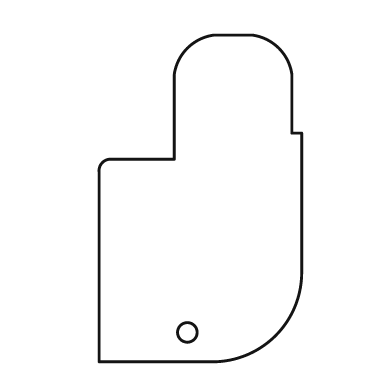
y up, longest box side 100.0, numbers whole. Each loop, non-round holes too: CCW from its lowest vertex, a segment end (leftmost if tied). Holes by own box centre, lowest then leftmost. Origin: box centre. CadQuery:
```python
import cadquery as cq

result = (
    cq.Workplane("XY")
    .moveTo(-31.0, -50.0)
    .lineTo(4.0, -50.0)
    .threePointArc((23.0, -42.0), (31.0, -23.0))
    .lineTo(31.0, 20.0)
    .lineTo(28.0, 20.0)
    .lineTo(28.0, 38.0)
    .threePointArc((24.0, 46.0), (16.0, 50.0))
    .lineTo(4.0, 50.0)
    .threePointArc((-4.0, 46.0), (-8.0, 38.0))
    .lineTo(-8.0, 12.0)
    .lineTo(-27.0, 12.0)
    .threePointArc((-30.0, 11.0), (-31.0, 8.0))
    .close()
    .moveTo(-4.0, -41.0)
    .circle(3.0)
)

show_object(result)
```